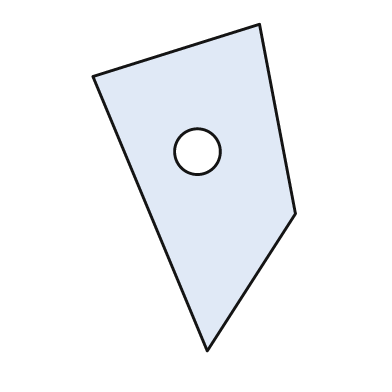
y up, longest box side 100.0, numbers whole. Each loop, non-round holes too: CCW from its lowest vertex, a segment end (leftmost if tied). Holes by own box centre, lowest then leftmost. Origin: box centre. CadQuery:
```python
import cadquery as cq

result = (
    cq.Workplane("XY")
    .moveTo(4.0, -50.0)
    .lineTo(31.0, -8.0)
    .lineTo(20.0, 50.0)
    .lineTo(-31.0, 34.0)
    .close()
    .moveTo(1.0, 11.0)
    .circle(7.0)
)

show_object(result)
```